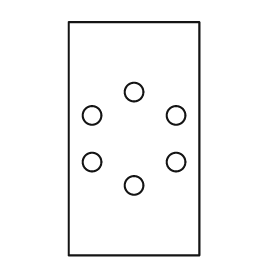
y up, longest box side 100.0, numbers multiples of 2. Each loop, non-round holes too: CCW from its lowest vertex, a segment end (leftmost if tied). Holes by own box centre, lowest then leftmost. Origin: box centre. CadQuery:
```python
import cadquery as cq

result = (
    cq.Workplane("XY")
    .moveTo(-28.0, -50.0)
    .lineTo(28.0, -50.0)
    .lineTo(28.0, 50.0)
    .lineTo(-28.0, 50.0)
    .close()
    .moveTo(0.0, -20.0)
    .circle(4.0)
    .moveTo(-18.0, -10.0)
    .circle(4.0)
    .moveTo(18.0, -10.0)
    .circle(4.0)
    .moveTo(-18.0, 10.0)
    .circle(4.0)
    .moveTo(18.0, 10.0)
    .circle(4.0)
    .moveTo(0.0, 20.0)
    .circle(4.0)
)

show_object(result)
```